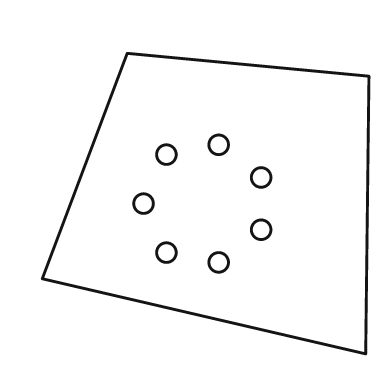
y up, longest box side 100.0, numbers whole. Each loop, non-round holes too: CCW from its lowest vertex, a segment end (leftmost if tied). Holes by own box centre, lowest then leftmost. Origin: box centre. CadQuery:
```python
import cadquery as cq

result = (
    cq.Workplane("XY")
    .moveTo(49.0, -46.0)
    .lineTo(50.0, 39.0)
    .lineTo(-24.0, 46.0)
    .lineTo(-50.0, -23.0)
    .close()
    .moveTo(4.0, -18.0)
    .circle(3.0)
    .moveTo(-12.0, -15.0)
    .circle(3.0)
    .moveTo(17.0, -8.0)
    .circle(3.0)
    .moveTo(-19.0, 0.0)
    .circle(3.0)
    .moveTo(17.0, 8.0)
    .circle(3.0)
    .moveTo(-12.0, 15.0)
    .circle(3.0)
    .moveTo(4.0, 18.0)
    .circle(3.0)
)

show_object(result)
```